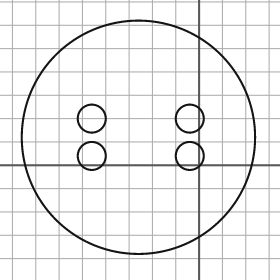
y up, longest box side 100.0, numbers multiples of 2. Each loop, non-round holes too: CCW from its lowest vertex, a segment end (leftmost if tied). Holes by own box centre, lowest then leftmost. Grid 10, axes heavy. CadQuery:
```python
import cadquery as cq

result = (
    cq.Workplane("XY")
    .moveTo(-26.0, 12.0)
    .circle(50.0)
    .moveTo(-46.0, 4.0)
    .circle(6.0)
    .moveTo(-4.0, 4.0)
    .circle(6.0)
    .moveTo(-46.0, 20.0)
    .circle(6.0)
    .moveTo(-4.0, 20.0)
    .circle(6.0)
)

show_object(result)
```